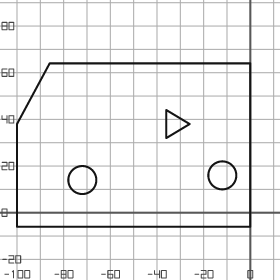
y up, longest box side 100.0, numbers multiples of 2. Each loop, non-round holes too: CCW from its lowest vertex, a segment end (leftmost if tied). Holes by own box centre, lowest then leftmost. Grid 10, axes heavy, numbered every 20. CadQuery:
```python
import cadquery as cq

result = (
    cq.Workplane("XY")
    .moveTo(-100.0, -6.0)
    .lineTo(0.0, -6.0)
    .lineTo(0.0, 64.0)
    .lineTo(-86.0, 64.0)
    .lineTo(-100.0, 38.0)
    .close()
    .moveTo(-72.0, 14.0)
    .circle(6.0)
    .moveTo(-12.0, 16.0)
    .circle(6.0)
    .moveTo(-36.0, 32.0)
    .lineTo(-26.0, 38.0)
    .lineTo(-36.0, 44.0)
    .close()
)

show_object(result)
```